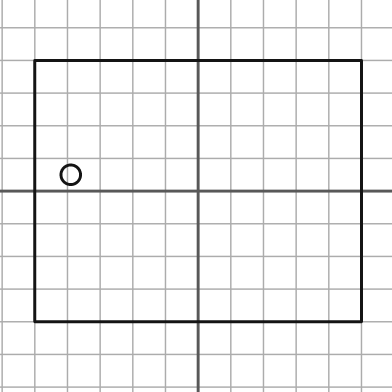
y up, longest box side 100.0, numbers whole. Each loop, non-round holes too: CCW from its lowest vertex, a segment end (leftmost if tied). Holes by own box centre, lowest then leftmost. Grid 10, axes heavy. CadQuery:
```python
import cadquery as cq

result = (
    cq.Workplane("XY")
    .moveTo(-50.0, -40.0)
    .lineTo(50.0, -40.0)
    .lineTo(50.0, 40.0)
    .lineTo(-50.0, 40.0)
    .close()
    .moveTo(-39.0, 5.0)
    .circle(3.0)
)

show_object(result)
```